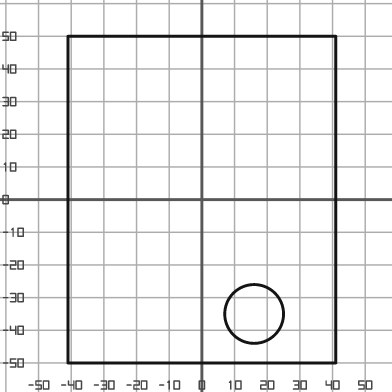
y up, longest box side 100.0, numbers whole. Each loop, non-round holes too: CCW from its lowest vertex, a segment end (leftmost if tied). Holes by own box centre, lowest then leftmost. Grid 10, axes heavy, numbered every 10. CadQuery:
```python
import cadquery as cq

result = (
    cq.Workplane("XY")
    .moveTo(-41.0, -50.0)
    .lineTo(41.0, -50.0)
    .lineTo(41.0, 50.0)
    .lineTo(-41.0, 50.0)
    .close()
    .moveTo(16.0, -35.0)
    .circle(9.0)
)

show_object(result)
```